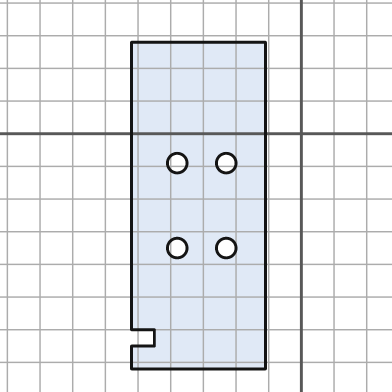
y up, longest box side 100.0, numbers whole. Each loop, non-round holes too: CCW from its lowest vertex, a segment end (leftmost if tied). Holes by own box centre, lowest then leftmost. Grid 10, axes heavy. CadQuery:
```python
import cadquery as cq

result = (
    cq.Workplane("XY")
    .moveTo(-52.0, -72.0)
    .lineTo(-11.0, -72.0)
    .lineTo(-11.0, 28.0)
    .lineTo(-52.0, 28.0)
    .lineTo(-52.0, -60.0)
    .lineTo(-45.0, -60.0)
    .lineTo(-45.0, -65.0)
    .lineTo(-52.0, -65.0)
    .close()
    .moveTo(-38.0, -35.0)
    .circle(3.0)
    .moveTo(-23.0, -35.0)
    .circle(3.0)
    .moveTo(-38.0, -9.0)
    .circle(3.0)
    .moveTo(-23.0, -9.0)
    .circle(3.0)
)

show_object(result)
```